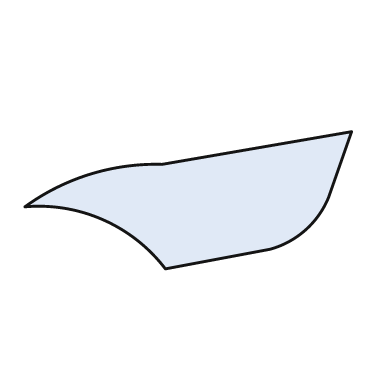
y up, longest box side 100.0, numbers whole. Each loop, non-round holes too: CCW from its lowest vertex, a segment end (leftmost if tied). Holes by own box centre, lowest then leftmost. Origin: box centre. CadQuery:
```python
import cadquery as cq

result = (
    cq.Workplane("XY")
    .moveTo(-7.0, -21.0)
    .lineTo(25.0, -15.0)
    .threePointArc((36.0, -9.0), (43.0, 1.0))
    .lineTo(50.0, 21.0)
    .lineTo(-8.0, 11.0)
    .threePointArc((-30.0, 8.0), (-50.0, -2.0))
    .threePointArc((-26.0, -6.0), (-7.0, -21.0))
    .close()
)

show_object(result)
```